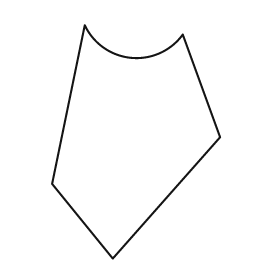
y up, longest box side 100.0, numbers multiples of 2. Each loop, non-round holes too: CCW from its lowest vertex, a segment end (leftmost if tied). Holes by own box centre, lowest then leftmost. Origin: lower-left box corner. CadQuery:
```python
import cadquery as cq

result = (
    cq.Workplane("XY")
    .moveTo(26.0, 0.0)
    .lineTo(72.0, 52.0)
    .lineTo(56.0, 96.0)
    .threePointArc((34.0, 86.0), (14.0, 100.0))
    .lineTo(0.0, 32.0)
    .close()
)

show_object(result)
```